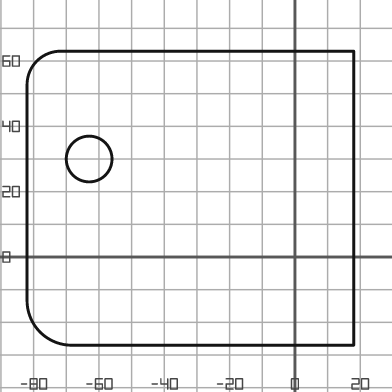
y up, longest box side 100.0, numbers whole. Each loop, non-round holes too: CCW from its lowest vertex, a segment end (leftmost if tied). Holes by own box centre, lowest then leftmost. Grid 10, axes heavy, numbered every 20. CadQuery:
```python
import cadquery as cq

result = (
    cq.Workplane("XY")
    .moveTo(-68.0, -27.0)
    .lineTo(18.0, -27.0)
    .lineTo(18.0, 63.0)
    .lineTo(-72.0, 63.0)
    .threePointArc((-79.0, 60.0), (-82.0, 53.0))
    .lineTo(-82.0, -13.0)
    .threePointArc((-78.0, -23.0), (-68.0, -27.0))
    .close()
    .moveTo(-63.0, 30.0)
    .circle(7.0)
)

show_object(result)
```